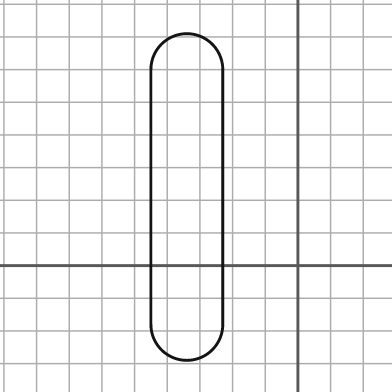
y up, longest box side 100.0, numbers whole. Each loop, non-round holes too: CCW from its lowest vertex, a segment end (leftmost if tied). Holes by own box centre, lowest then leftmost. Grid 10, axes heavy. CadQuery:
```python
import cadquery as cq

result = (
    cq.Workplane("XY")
    .moveTo(-45.0, -18.0)
    .threePointArc((-34.0, -29.0), (-23.0, -18.0))
    .lineTo(-23.0, 60.0)
    .threePointArc((-34.0, 71.0), (-45.0, 60.0))
    .close()
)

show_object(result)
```